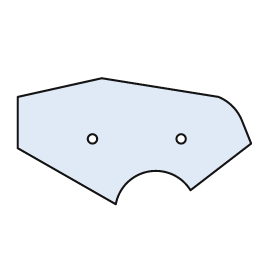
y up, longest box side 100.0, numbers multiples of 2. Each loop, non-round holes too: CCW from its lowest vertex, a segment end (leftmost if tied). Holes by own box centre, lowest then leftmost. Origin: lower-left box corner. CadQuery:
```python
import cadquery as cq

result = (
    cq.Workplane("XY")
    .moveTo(42.0, 0.0)
    .threePointArc((56.0, 14.0), (74.0, 6.0))
    .lineTo(100.0, 26.0)
    .lineTo(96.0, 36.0)
    .threePointArc((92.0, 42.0), (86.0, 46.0))
    .lineTo(36.0, 54.0)
    .lineTo(0.0, 46.0)
    .lineTo(0.0, 24.0)
    .close()
    .moveTo(32.0, 28.0)
    .circle(2.0)
    .moveTo(70.0, 28.0)
    .circle(2.0)
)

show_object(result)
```